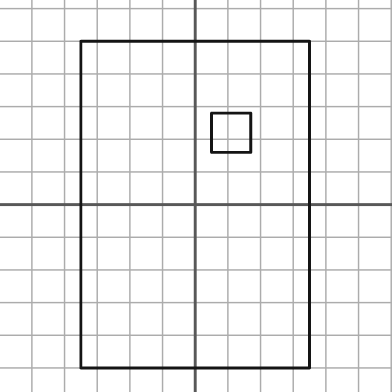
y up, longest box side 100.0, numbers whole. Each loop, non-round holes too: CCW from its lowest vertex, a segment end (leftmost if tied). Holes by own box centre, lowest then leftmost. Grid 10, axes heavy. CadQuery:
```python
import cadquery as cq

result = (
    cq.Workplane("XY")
    .moveTo(-35.0, -50.0)
    .lineTo(35.0, -50.0)
    .lineTo(35.0, 50.0)
    .lineTo(-35.0, 50.0)
    .close()
    .moveTo(5.0, 16.0)
    .lineTo(17.0, 16.0)
    .lineTo(17.0, 28.0)
    .lineTo(5.0, 28.0)
    .close()
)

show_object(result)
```